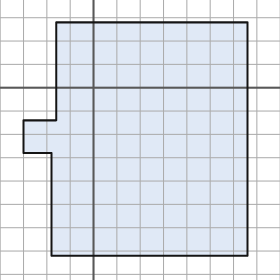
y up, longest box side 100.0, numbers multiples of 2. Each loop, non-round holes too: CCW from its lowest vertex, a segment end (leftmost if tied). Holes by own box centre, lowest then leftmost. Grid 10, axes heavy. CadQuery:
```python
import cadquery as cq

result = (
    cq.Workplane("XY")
    .moveTo(-18.0, -72.0)
    .lineTo(66.0, -72.0)
    .lineTo(66.0, 28.0)
    .lineTo(-16.0, 28.0)
    .lineTo(-16.0, -14.0)
    .lineTo(-30.0, -14.0)
    .lineTo(-30.0, -28.0)
    .lineTo(-18.0, -28.0)
    .close()
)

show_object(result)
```